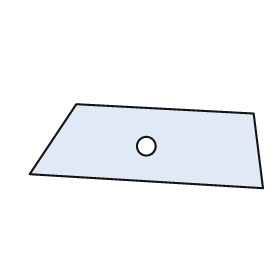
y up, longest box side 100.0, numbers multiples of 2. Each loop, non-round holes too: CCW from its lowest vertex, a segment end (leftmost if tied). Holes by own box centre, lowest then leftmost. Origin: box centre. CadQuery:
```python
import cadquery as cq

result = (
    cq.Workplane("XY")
    .moveTo(50.0, -18.0)
    .lineTo(46.0, 14.0)
    .lineTo(-30.0, 18.0)
    .lineTo(-50.0, -12.0)
    .close()
    .moveTo(0.0, 0.0)
    .circle(4.0)
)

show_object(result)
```